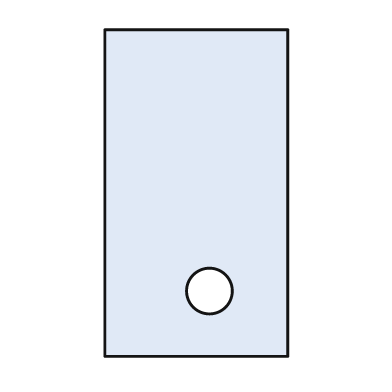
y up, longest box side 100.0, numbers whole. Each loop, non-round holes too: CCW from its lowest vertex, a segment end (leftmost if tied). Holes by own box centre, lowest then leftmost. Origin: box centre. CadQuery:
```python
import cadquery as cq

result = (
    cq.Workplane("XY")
    .moveTo(-28.0, -50.0)
    .lineTo(28.0, -50.0)
    .lineTo(28.0, 50.0)
    .lineTo(-28.0, 50.0)
    .close()
    .moveTo(4.0, -30.0)
    .circle(7.0)
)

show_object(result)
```